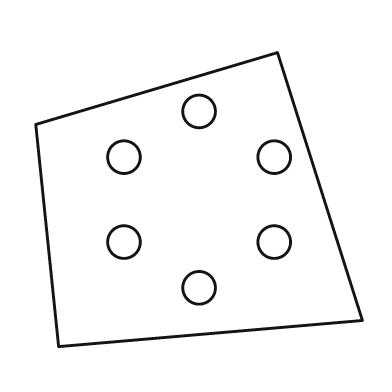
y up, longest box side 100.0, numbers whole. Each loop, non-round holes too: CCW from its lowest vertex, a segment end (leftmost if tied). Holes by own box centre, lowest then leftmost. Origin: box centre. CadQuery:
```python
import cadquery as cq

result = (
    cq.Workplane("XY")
    .moveTo(-43.0, -45.0)
    .lineTo(50.0, -37.0)
    .lineTo(24.0, 45.0)
    .lineTo(-50.0, 23.0)
    .close()
    .moveTo(0.0, -27.0)
    .circle(5.0)
    .moveTo(-23.0, -13.0)
    .circle(5.0)
    .moveTo(23.0, -13.0)
    .circle(5.0)
    .moveTo(-23.0, 13.0)
    .circle(5.0)
    .moveTo(23.0, 13.0)
    .circle(5.0)
    .moveTo(0.0, 27.0)
    .circle(5.0)
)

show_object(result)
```